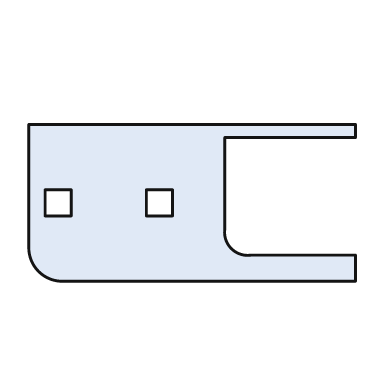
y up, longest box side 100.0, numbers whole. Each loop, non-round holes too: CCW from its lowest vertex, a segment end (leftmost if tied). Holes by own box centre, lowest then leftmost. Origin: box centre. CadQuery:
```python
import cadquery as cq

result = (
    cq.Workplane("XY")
    .moveTo(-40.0, -24.0)
    .lineTo(50.0, -24.0)
    .lineTo(50.0, -16.0)
    .lineTo(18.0, -16.0)
    .threePointArc((12.0, -14.0), (10.0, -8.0))
    .lineTo(10.0, 20.0)
    .lineTo(50.0, 20.0)
    .lineTo(50.0, 24.0)
    .lineTo(-50.0, 24.0)
    .lineTo(-50.0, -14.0)
    .threePointArc((-47.0, -21.0), (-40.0, -24.0))
    .close()
    .moveTo(-45.0, -4.0)
    .lineTo(-37.0, -4.0)
    .lineTo(-37.0, 4.0)
    .lineTo(-45.0, 4.0)
    .close()
    .moveTo(-14.0, -4.0)
    .lineTo(-6.0, -4.0)
    .lineTo(-6.0, 4.0)
    .lineTo(-14.0, 4.0)
    .close()
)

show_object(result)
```